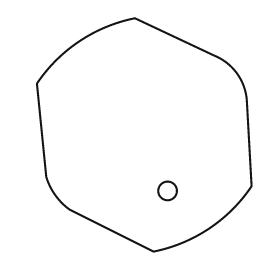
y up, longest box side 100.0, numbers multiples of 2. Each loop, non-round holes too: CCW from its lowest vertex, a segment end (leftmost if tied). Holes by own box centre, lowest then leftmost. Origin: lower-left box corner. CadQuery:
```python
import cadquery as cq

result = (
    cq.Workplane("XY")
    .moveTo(50.0, 0.0)
    .threePointArc((74.0, 10.0), (92.0, 28.0))
    .lineTo(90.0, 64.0)
    .threePointArc((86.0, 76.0), (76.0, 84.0))
    .lineTo(42.0, 100.0)
    .threePointArc((18.0, 90.0), (0.0, 72.0))
    .lineTo(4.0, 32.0)
    .threePointArc((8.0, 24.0), (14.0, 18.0))
    .close()
    .moveTo(56.0, 26.0)
    .circle(4.0)
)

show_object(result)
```